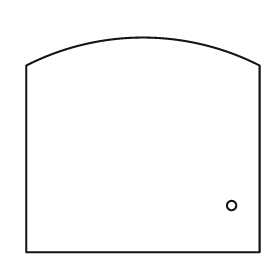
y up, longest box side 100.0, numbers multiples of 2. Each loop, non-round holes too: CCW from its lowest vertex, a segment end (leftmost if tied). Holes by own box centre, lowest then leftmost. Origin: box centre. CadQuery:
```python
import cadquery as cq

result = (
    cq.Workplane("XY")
    .moveTo(-50.0, -46.0)
    .lineTo(50.0, -46.0)
    .lineTo(50.0, 34.0)
    .threePointArc((0.0, 46.0), (-50.0, 34.0))
    .close()
    .moveTo(38.0, -26.0)
    .circle(2.0)
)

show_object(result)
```